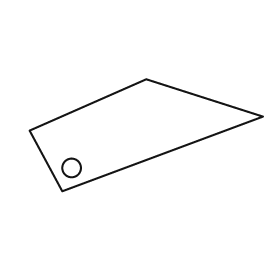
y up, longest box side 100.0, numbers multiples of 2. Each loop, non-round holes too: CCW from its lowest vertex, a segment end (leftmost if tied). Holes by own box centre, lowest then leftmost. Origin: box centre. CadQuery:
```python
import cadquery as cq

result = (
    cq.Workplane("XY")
    .moveTo(-36.0, -24.0)
    .lineTo(50.0, 8.0)
    .lineTo(0.0, 24.0)
    .lineTo(-50.0, 2.0)
    .close()
    .moveTo(-32.0, -14.0)
    .circle(4.0)
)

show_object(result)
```